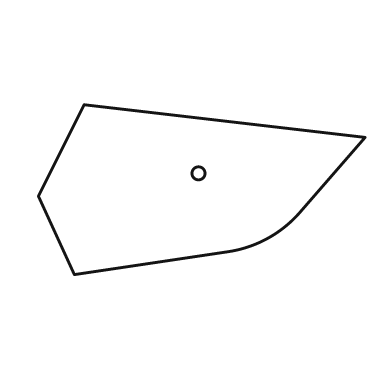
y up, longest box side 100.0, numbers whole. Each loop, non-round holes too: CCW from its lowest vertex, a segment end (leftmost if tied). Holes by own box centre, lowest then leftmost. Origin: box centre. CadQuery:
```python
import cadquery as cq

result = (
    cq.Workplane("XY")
    .moveTo(-39.0, -26.0)
    .lineTo(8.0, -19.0)
    .threePointArc((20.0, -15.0), (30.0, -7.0))
    .lineTo(50.0, 16.0)
    .lineTo(-36.0, 26.0)
    .lineTo(-50.0, -2.0)
    .close()
    .moveTo(-1.0, 5.0)
    .circle(2.0)
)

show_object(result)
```